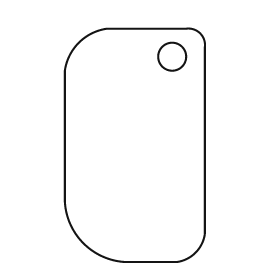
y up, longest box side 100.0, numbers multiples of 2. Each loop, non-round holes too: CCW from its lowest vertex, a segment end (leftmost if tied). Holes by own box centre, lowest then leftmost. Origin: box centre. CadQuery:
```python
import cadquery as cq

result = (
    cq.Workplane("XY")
    .moveTo(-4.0, -50.0)
    .lineTo(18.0, -50.0)
    .threePointArc((26.0, -46.0), (30.0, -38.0))
    .lineTo(30.0, 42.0)
    .threePointArc((28.0, 48.0), (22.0, 50.0))
    .lineTo(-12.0, 50.0)
    .threePointArc((-24.0, 44.0), (-30.0, 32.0))
    .lineTo(-30.0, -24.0)
    .threePointArc((-22.0, -42.0), (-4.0, -50.0))
    .close()
    .moveTo(16.0, 38.0)
    .circle(6.0)
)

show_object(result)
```